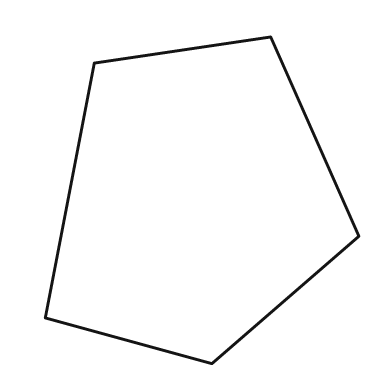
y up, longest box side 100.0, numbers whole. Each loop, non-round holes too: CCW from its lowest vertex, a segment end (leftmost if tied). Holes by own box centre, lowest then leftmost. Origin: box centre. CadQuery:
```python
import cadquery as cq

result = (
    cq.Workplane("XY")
    .moveTo(3.0, -50.0)
    .lineTo(48.0, -11.0)
    .lineTo(21.0, 50.0)
    .lineTo(-33.0, 42.0)
    .lineTo(-48.0, -36.0)
    .close()
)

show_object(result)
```